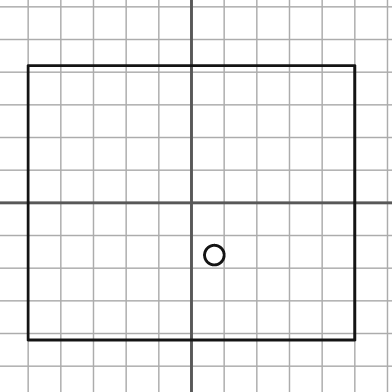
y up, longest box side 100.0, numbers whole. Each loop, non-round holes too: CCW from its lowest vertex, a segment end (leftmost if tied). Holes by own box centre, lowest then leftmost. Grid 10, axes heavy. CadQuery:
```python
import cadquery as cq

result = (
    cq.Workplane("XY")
    .moveTo(-50.0, -42.0)
    .lineTo(50.0, -42.0)
    .lineTo(50.0, 42.0)
    .lineTo(-50.0, 42.0)
    .close()
    .moveTo(7.0, -16.0)
    .circle(3.0)
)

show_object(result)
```